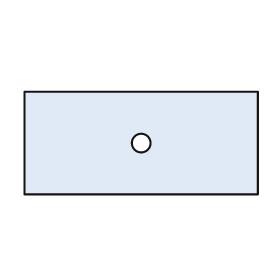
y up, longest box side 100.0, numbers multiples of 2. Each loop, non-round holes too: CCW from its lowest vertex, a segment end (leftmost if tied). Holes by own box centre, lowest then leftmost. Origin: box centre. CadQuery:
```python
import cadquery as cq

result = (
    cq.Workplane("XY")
    .moveTo(-50.0, -22.0)
    .lineTo(50.0, -22.0)
    .lineTo(50.0, 22.0)
    .lineTo(-50.0, 22.0)
    .close()
    .moveTo(0.0, 0.0)
    .circle(4.0)
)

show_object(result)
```